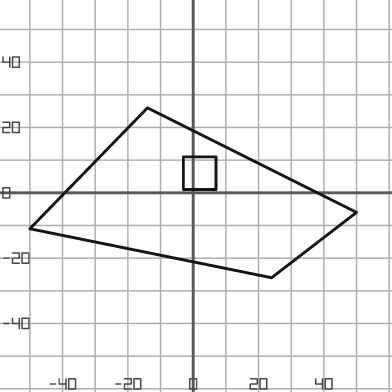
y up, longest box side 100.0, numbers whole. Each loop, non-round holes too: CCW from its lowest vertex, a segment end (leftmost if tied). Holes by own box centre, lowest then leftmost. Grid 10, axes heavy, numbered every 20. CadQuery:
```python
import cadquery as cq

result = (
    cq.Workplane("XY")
    .moveTo(24.0, -26.0)
    .lineTo(50.0, -6.0)
    .lineTo(-14.0, 26.0)
    .lineTo(-50.0, -11.0)
    .close()
    .moveTo(-3.0, 1.0)
    .lineTo(7.0, 1.0)
    .lineTo(7.0, 11.0)
    .lineTo(-3.0, 11.0)
    .close()
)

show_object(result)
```